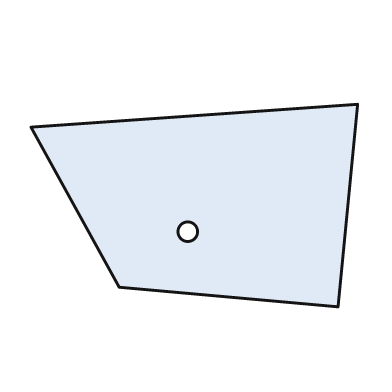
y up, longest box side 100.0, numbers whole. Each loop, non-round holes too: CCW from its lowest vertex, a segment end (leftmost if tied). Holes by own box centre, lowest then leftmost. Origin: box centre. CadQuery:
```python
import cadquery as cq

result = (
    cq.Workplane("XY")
    .moveTo(44.0, -31.0)
    .lineTo(50.0, 31.0)
    .lineTo(-50.0, 24.0)
    .lineTo(-23.0, -25.0)
    .close()
    .moveTo(-2.0, -8.0)
    .circle(3.0)
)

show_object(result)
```